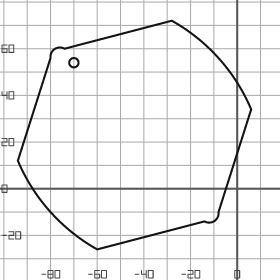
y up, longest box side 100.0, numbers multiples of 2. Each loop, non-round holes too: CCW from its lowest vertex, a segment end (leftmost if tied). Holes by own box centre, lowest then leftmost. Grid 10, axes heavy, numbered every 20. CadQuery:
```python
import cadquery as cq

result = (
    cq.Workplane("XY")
    .moveTo(-60.0, -26.0)
    .lineTo(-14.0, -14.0)
    .threePointArc((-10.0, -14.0), (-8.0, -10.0))
    .lineTo(6.0, 34.0)
    .threePointArc((-8.0, 56.0), (-28.0, 72.0))
    .lineTo(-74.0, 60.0)
    .threePointArc((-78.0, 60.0), (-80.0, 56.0))
    .lineTo(-94.0, 12.0)
    .threePointArc((-80.0, -10.0), (-60.0, -26.0))
    .close()
    .moveTo(-70.0, 54.0)
    .circle(2.0)
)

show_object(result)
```